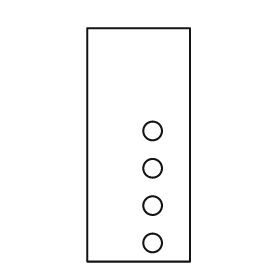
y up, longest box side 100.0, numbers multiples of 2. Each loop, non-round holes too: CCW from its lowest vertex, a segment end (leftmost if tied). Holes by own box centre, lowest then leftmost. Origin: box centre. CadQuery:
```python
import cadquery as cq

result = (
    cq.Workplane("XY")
    .moveTo(-22.0, -50.0)
    .lineTo(22.0, -50.0)
    .lineTo(22.0, 50.0)
    .lineTo(-22.0, 50.0)
    .close()
    .moveTo(6.0, -42.0)
    .circle(4.0)
    .moveTo(6.0, -26.0)
    .circle(4.0)
    .moveTo(6.0, -10.0)
    .circle(4.0)
    .moveTo(6.0, 6.0)
    .circle(4.0)
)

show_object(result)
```